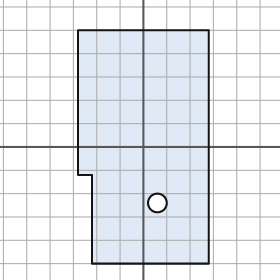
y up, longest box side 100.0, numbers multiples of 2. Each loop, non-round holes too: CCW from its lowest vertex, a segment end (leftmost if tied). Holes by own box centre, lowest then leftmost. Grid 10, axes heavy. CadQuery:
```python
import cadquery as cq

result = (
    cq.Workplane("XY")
    .moveTo(-22.0, -50.0)
    .lineTo(28.0, -50.0)
    .lineTo(28.0, 50.0)
    .lineTo(-28.0, 50.0)
    .lineTo(-28.0, -12.0)
    .lineTo(-22.0, -12.0)
    .close()
    .moveTo(6.0, -24.0)
    .circle(4.0)
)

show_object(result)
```